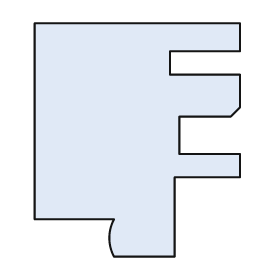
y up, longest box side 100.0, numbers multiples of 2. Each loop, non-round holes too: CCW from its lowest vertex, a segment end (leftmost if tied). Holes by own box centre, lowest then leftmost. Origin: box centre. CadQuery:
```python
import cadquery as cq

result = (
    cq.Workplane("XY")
    .moveTo(-10.0, -50.0)
    .lineTo(16.0, -50.0)
    .lineTo(16.0, -16.0)
    .lineTo(44.0, -16.0)
    .lineTo(44.0, -6.0)
    .lineTo(18.0, -6.0)
    .lineTo(18.0, 10.0)
    .lineTo(40.0, 10.0)
    .lineTo(44.0, 14.0)
    .lineTo(44.0, 28.0)
    .lineTo(14.0, 28.0)
    .lineTo(14.0, 38.0)
    .lineTo(44.0, 38.0)
    .lineTo(44.0, 50.0)
    .lineTo(-44.0, 50.0)
    .lineTo(-44.0, -34.0)
    .lineTo(-10.0, -34.0)
    .threePointArc((-12.0, -42.0), (-10.0, -50.0))
    .close()
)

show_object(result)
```